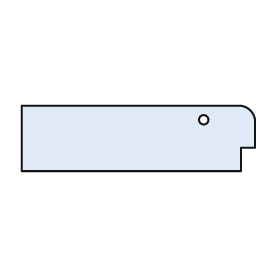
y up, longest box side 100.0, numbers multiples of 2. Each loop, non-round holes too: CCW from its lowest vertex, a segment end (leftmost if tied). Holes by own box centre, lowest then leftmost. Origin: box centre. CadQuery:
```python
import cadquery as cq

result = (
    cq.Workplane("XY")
    .moveTo(-50.0, -14.0)
    .lineTo(44.0, -14.0)
    .lineTo(44.0, -4.0)
    .lineTo(50.0, -4.0)
    .lineTo(50.0, 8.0)
    .threePointArc((48.0, 12.0), (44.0, 14.0))
    .lineTo(-50.0, 14.0)
    .close()
    .moveTo(28.0, 8.0)
    .circle(2.0)
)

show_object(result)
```